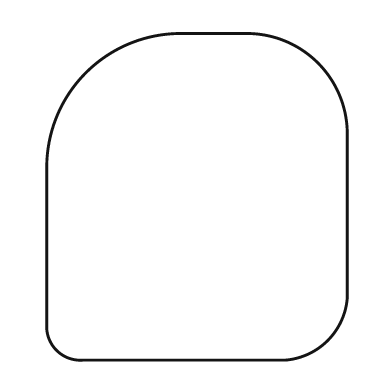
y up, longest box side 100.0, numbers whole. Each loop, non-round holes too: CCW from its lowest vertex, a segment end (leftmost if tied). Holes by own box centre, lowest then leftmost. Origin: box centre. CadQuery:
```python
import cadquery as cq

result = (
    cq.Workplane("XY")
    .moveTo(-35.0, -50.0)
    .lineTo(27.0, -50.0)
    .threePointArc((40.0, -44.0), (46.0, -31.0))
    .lineTo(46.0, 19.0)
    .threePointArc((37.0, 41.0), (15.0, 50.0))
    .lineTo(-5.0, 50.0)
    .threePointArc((-34.0, 38.0), (-46.0, 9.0))
    .lineTo(-46.0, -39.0)
    .threePointArc((-43.0, -47.0), (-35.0, -50.0))
    .close()
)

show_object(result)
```